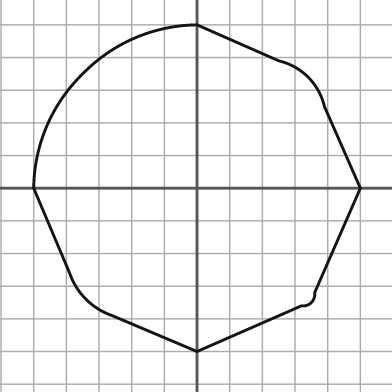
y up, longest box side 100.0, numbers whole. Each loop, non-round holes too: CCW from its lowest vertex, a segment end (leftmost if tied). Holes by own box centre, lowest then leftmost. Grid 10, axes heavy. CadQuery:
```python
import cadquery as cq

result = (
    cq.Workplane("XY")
    .moveTo(0.0, -50.0)
    .lineTo(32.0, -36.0)
    .threePointArc((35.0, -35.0), (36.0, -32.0))
    .lineTo(50.0, 0.0)
    .lineTo(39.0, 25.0)
    .threePointArc((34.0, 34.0), (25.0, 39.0))
    .lineTo(0.0, 50.0)
    .threePointArc((-19.0, 46.0), (-35.0, 35.0))
    .threePointArc((-46.0, 19.0), (-50.0, 0.0))
    .lineTo(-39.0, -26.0)
    .threePointArc((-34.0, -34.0), (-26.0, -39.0))
    .close()
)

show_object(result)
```